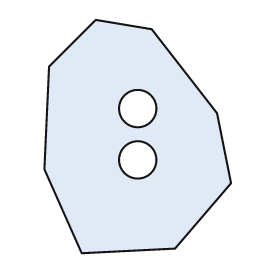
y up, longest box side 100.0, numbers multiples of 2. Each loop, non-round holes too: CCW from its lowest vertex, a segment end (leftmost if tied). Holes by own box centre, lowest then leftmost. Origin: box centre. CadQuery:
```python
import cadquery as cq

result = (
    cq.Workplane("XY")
    .moveTo(-24.0, -50.0)
    .lineTo(16.0, -48.0)
    .lineTo(40.0, -20.0)
    .lineTo(34.0, 10.0)
    .lineTo(6.0, 46.0)
    .lineTo(-18.0, 50.0)
    .lineTo(-38.0, 30.0)
    .lineTo(-40.0, -14.0)
    .close()
    .moveTo(0.0, -10.0)
    .circle(8.0)
    .moveTo(0.0, 12.0)
    .circle(8.0)
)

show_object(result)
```